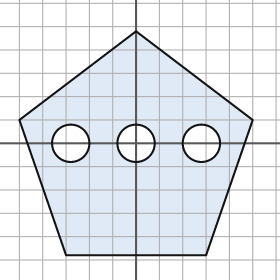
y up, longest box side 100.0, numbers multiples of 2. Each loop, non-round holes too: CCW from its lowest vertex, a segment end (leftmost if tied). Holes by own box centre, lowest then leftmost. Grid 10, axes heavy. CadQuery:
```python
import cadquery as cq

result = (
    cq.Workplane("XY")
    .moveTo(-30.0, -48.0)
    .lineTo(30.0, -48.0)
    .lineTo(50.0, 10.0)
    .lineTo(0.0, 48.0)
    .lineTo(-50.0, 10.0)
    .close()
    .moveTo(-28.0, 0.0)
    .circle(8.0)
    .moveTo(0.0, 0.0)
    .circle(8.0)
    .moveTo(28.0, 0.0)
    .circle(8.0)
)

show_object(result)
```